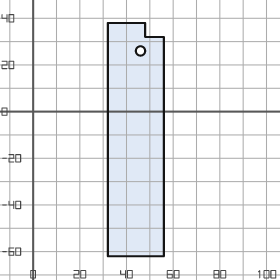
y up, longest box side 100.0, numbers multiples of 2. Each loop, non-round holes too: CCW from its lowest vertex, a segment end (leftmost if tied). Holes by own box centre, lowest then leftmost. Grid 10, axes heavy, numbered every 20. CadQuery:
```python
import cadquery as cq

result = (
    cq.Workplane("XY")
    .moveTo(32.0, -62.0)
    .lineTo(56.0, -62.0)
    .lineTo(56.0, 32.0)
    .lineTo(48.0, 32.0)
    .lineTo(48.0, 38.0)
    .lineTo(32.0, 38.0)
    .close()
    .moveTo(46.0, 26.0)
    .circle(2.0)
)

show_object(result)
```